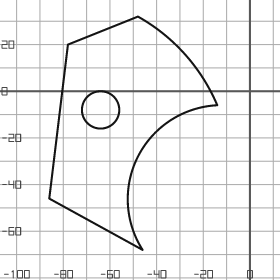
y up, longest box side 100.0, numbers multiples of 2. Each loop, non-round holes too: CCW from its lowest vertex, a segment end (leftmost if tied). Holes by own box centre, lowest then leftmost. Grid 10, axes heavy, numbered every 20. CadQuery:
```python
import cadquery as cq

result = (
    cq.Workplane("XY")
    .moveTo(-46.0, -68.0)
    .threePointArc((-48.0, -28.0), (-14.0, -6.0))
    .threePointArc((-28.0, 16.0), (-48.0, 32.0))
    .lineTo(-78.0, 20.0)
    .lineTo(-86.0, -46.0)
    .close()
    .moveTo(-64.0, -8.0)
    .circle(8.0)
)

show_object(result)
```